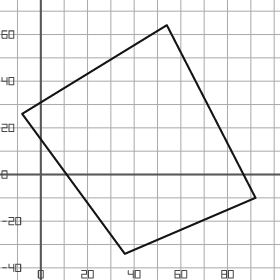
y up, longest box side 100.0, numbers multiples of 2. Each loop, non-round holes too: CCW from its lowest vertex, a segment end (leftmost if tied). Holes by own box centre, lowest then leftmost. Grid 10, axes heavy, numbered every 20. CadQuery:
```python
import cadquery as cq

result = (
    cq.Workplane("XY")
    .moveTo(36.0, -34.0)
    .lineTo(92.0, -10.0)
    .lineTo(54.0, 64.0)
    .lineTo(-8.0, 26.0)
    .close()
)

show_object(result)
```